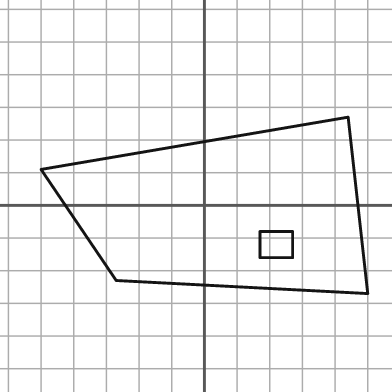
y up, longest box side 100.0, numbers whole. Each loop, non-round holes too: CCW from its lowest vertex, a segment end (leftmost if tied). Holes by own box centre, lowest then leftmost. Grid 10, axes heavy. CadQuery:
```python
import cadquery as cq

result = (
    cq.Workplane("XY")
    .moveTo(50.0, -27.0)
    .lineTo(44.0, 27.0)
    .lineTo(-50.0, 11.0)
    .lineTo(-27.0, -23.0)
    .close()
    .moveTo(17.0, -16.0)
    .lineTo(27.0, -16.0)
    .lineTo(27.0, -8.0)
    .lineTo(17.0, -8.0)
    .close()
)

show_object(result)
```